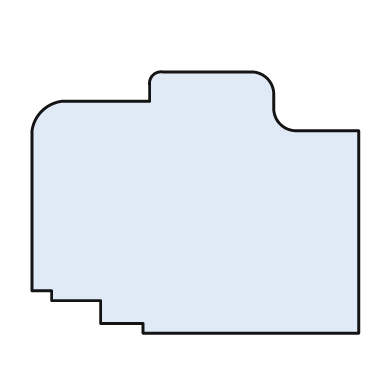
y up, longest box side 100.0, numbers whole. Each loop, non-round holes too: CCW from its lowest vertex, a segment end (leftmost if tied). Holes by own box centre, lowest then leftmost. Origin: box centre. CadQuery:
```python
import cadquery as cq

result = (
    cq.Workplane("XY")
    .moveTo(-16.0, -40.0)
    .lineTo(50.0, -40.0)
    .lineTo(50.0, 22.0)
    .lineTo(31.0, 22.0)
    .threePointArc((26.0, 24.0), (24.0, 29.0))
    .lineTo(24.0, 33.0)
    .threePointArc((22.0, 38.0), (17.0, 40.0))
    .lineTo(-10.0, 40.0)
    .threePointArc((-13.0, 39.0), (-14.0, 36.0))
    .lineTo(-14.0, 31.0)
    .lineTo(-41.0, 31.0)
    .threePointArc((-47.0, 28.0), (-50.0, 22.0))
    .lineTo(-50.0, -27.0)
    .lineTo(-44.0, -27.0)
    .lineTo(-44.0, -30.0)
    .lineTo(-29.0, -30.0)
    .lineTo(-29.0, -37.0)
    .lineTo(-16.0, -37.0)
    .close()
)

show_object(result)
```